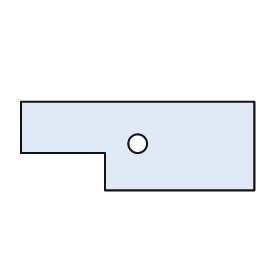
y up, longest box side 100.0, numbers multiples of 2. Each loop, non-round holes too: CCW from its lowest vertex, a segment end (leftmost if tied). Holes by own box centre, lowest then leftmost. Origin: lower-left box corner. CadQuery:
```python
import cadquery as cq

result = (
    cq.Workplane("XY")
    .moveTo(36.0, 0.0)
    .lineTo(100.0, 0.0)
    .lineTo(100.0, 38.0)
    .lineTo(0.0, 38.0)
    .lineTo(0.0, 16.0)
    .lineTo(36.0, 16.0)
    .close()
    .moveTo(50.0, 20.0)
    .circle(4.0)
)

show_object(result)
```